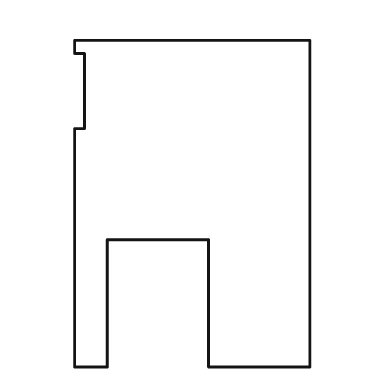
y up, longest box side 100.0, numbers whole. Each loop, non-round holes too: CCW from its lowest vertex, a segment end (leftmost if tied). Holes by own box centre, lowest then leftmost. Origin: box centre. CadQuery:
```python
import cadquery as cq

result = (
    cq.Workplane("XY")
    .moveTo(-36.0, -50.0)
    .lineTo(-26.0, -50.0)
    .lineTo(-26.0, -11.0)
    .lineTo(5.0, -11.0)
    .lineTo(5.0, -50.0)
    .lineTo(36.0, -50.0)
    .lineTo(36.0, 50.0)
    .lineTo(-36.0, 50.0)
    .lineTo(-36.0, 46.0)
    .lineTo(-33.0, 46.0)
    .lineTo(-33.0, 23.0)
    .lineTo(-36.0, 23.0)
    .close()
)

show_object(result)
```